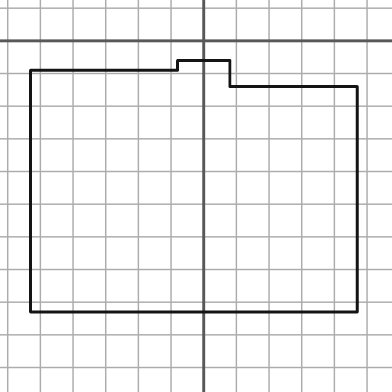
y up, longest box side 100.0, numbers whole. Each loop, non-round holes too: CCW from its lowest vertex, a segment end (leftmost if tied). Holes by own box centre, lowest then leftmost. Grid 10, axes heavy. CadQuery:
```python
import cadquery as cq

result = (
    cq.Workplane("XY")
    .moveTo(-53.0, -83.0)
    .lineTo(47.0, -83.0)
    .lineTo(47.0, -14.0)
    .lineTo(8.0, -14.0)
    .lineTo(8.0, -6.0)
    .lineTo(-8.0, -6.0)
    .lineTo(-8.0, -9.0)
    .lineTo(-53.0, -9.0)
    .close()
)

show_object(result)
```